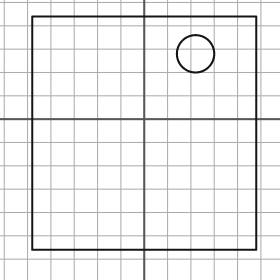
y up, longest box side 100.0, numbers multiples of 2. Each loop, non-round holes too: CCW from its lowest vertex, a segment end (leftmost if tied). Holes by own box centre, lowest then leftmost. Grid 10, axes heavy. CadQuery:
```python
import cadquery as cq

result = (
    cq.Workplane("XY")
    .moveTo(-48.0, -56.0)
    .lineTo(48.0, -56.0)
    .lineTo(48.0, 44.0)
    .lineTo(-48.0, 44.0)
    .close()
    .moveTo(22.0, 28.0)
    .circle(8.0)
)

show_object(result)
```